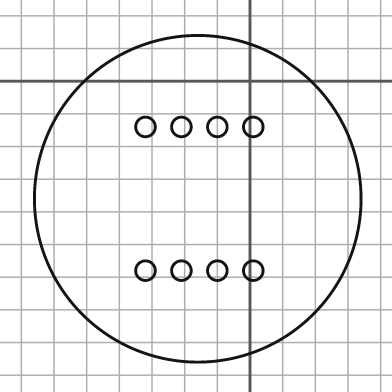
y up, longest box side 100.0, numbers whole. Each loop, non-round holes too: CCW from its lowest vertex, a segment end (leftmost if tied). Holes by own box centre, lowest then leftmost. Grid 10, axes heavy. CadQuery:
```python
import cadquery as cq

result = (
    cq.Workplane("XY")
    .moveTo(-16.0, -36.0)
    .circle(50.0)
    .moveTo(-32.0, -58.0)
    .circle(3.0)
    .moveTo(-21.0, -58.0)
    .circle(3.0)
    .moveTo(-10.0, -58.0)
    .circle(3.0)
    .moveTo(1.0, -58.0)
    .circle(3.0)
    .moveTo(-32.0, -14.0)
    .circle(3.0)
    .moveTo(-21.0, -14.0)
    .circle(3.0)
    .moveTo(-10.0, -14.0)
    .circle(3.0)
    .moveTo(1.0, -14.0)
    .circle(3.0)
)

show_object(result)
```